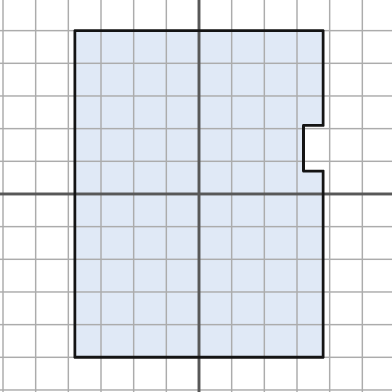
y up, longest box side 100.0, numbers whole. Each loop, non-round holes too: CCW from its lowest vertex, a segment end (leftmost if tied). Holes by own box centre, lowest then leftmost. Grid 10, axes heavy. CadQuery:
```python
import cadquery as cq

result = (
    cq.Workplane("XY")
    .moveTo(-38.0, -50.0)
    .lineTo(38.0, -50.0)
    .lineTo(38.0, 7.0)
    .lineTo(32.0, 7.0)
    .lineTo(32.0, 21.0)
    .lineTo(38.0, 21.0)
    .lineTo(38.0, 50.0)
    .lineTo(-38.0, 50.0)
    .close()
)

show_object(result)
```